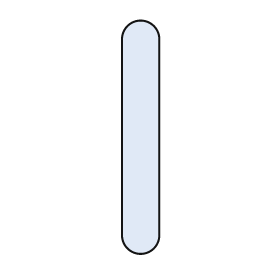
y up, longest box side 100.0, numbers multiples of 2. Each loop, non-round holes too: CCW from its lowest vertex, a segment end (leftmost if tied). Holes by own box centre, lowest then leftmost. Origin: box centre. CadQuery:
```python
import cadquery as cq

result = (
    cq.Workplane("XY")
    .moveTo(-8.0, -42.0)
    .threePointArc((0.0, -50.0), (8.0, -42.0))
    .lineTo(8.0, 42.0)
    .threePointArc((0.0, 50.0), (-8.0, 42.0))
    .close()
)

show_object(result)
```